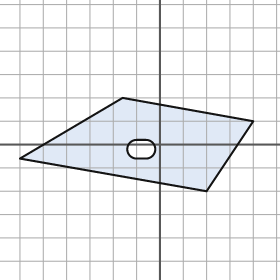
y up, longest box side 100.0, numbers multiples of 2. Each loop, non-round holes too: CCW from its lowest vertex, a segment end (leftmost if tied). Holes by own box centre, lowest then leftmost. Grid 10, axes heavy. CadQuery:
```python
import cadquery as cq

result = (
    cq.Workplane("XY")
    .moveTo(20.0, -20.0)
    .lineTo(40.0, 10.0)
    .lineTo(-16.0, 20.0)
    .lineTo(-60.0, -6.0)
    .close()
    .moveTo(-10.0, -6.0)
    .lineTo(-6.0, -6.0)
    .threePointArc((-2.0, -2.0), (-6.0, 2.0))
    .lineTo(-10.0, 2.0)
    .threePointArc((-14.0, -2.0), (-10.0, -6.0))
    .close()
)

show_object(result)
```